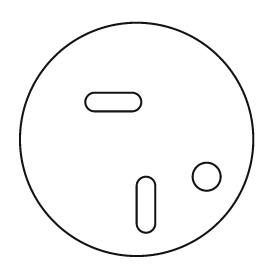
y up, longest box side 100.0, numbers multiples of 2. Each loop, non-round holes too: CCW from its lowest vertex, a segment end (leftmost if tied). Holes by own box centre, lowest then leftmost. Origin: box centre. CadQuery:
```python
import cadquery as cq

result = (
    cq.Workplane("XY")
    .moveTo(0.0, 0.0)
    .circle(50.0)
    .moveTo(0.0, -36.0)
    .threePointArc((4.0, -40.0), (8.0, -36.0))
    .lineTo(8.0, -20.0)
    .threePointArc((4.0, -16.0), (0.0, -20.0))
    .close()
    .moveTo(30.0, -16.0)
    .circle(6.0)
    .moveTo(-18.0, 12.0)
    .lineTo(-2.0, 12.0)
    .threePointArc((2.0, 16.0), (-2.0, 20.0))
    .lineTo(-18.0, 20.0)
    .threePointArc((-22.0, 16.0), (-18.0, 12.0))
    .close()
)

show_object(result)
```